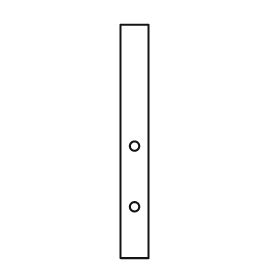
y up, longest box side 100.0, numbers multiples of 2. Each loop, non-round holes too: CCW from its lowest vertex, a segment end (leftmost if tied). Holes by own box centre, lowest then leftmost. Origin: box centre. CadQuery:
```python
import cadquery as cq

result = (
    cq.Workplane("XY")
    .moveTo(-6.0, -50.0)
    .lineTo(6.0, -50.0)
    .lineTo(6.0, 50.0)
    .lineTo(-6.0, 50.0)
    .close()
    .moveTo(0.0, -28.0)
    .circle(2.0)
    .moveTo(0.0, -2.0)
    .circle(2.0)
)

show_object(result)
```